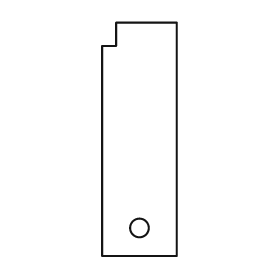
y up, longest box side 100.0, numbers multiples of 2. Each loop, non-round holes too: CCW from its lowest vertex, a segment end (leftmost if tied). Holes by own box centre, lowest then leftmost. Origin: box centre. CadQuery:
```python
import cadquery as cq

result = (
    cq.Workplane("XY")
    .moveTo(-16.0, -50.0)
    .lineTo(16.0, -50.0)
    .lineTo(16.0, 50.0)
    .lineTo(-10.0, 50.0)
    .lineTo(-10.0, 40.0)
    .lineTo(-16.0, 40.0)
    .close()
    .moveTo(0.0, -38.0)
    .circle(4.0)
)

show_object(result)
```